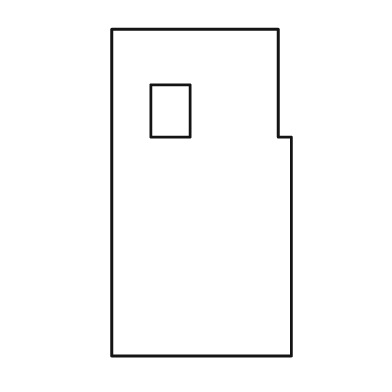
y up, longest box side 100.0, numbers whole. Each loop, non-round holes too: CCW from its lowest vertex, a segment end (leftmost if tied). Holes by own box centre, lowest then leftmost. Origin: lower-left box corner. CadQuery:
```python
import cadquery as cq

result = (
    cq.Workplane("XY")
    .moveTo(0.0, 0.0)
    .lineTo(55.0, 0.0)
    .lineTo(55.0, 67.0)
    .lineTo(51.0, 67.0)
    .lineTo(51.0, 100.0)
    .lineTo(0.0, 100.0)
    .close()
    .moveTo(12.0, 67.0)
    .lineTo(24.0, 67.0)
    .lineTo(24.0, 83.0)
    .lineTo(12.0, 83.0)
    .close()
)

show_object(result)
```